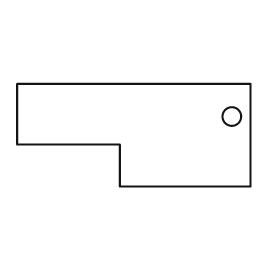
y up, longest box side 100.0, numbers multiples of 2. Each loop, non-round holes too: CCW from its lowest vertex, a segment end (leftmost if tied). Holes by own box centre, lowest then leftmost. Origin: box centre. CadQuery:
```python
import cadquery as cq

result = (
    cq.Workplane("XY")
    .moveTo(-6.0, -22.0)
    .lineTo(50.0, -22.0)
    .lineTo(50.0, 22.0)
    .lineTo(-50.0, 22.0)
    .lineTo(-50.0, -4.0)
    .lineTo(-6.0, -4.0)
    .close()
    .moveTo(42.0, 8.0)
    .circle(4.0)
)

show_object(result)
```